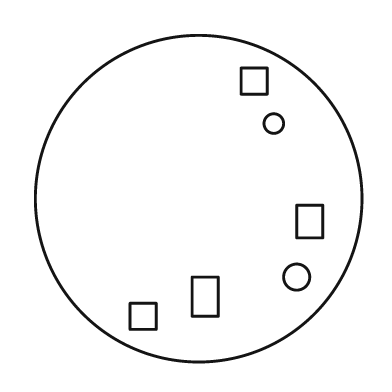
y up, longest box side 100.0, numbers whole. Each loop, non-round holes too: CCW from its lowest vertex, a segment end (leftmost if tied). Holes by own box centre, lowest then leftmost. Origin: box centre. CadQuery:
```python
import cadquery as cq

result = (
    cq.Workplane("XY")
    .moveTo(0.0, 0.0)
    .circle(50.0)
    .moveTo(-21.0, -40.0)
    .lineTo(-13.0, -40.0)
    .lineTo(-13.0, -32.0)
    .lineTo(-21.0, -32.0)
    .close()
    .moveTo(-2.0, -36.0)
    .lineTo(6.0, -36.0)
    .lineTo(6.0, -24.0)
    .lineTo(-2.0, -24.0)
    .close()
    .moveTo(30.0, -24.0)
    .circle(4.0)
    .moveTo(30.0, -12.0)
    .lineTo(38.0, -12.0)
    .lineTo(38.0, -2.0)
    .lineTo(30.0, -2.0)
    .close()
    .moveTo(23.0, 23.0)
    .circle(3.0)
    .moveTo(13.0, 32.0)
    .lineTo(21.0, 32.0)
    .lineTo(21.0, 40.0)
    .lineTo(13.0, 40.0)
    .close()
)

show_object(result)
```